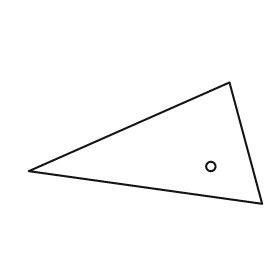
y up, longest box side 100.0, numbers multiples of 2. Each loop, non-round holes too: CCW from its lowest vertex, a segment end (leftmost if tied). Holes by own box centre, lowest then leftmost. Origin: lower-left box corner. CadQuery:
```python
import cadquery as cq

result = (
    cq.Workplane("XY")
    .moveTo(100.0, 0.0)
    .lineTo(86.0, 52.0)
    .lineTo(0.0, 14.0)
    .close()
    .moveTo(78.0, 16.0)
    .circle(2.0)
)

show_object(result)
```